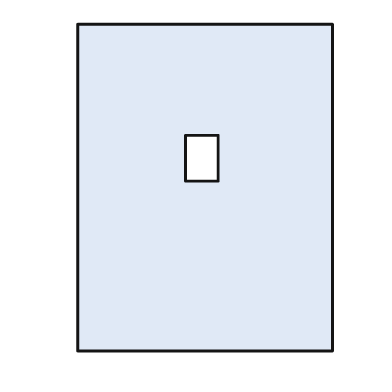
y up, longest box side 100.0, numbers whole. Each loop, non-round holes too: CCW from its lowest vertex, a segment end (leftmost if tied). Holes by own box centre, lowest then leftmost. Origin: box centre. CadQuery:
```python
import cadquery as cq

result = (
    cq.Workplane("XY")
    .moveTo(-39.0, -50.0)
    .lineTo(39.0, -50.0)
    .lineTo(39.0, 50.0)
    .lineTo(-39.0, 50.0)
    .close()
    .moveTo(-6.0, 2.0)
    .lineTo(4.0, 2.0)
    .lineTo(4.0, 16.0)
    .lineTo(-6.0, 16.0)
    .close()
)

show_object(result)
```